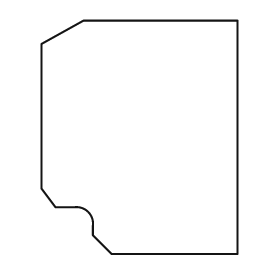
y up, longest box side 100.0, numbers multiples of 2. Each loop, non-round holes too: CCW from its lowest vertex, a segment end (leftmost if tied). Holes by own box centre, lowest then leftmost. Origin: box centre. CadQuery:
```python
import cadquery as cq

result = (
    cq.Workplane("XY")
    .moveTo(-12.0, -50.0)
    .lineTo(42.0, -50.0)
    .lineTo(42.0, 50.0)
    .lineTo(-24.0, 50.0)
    .lineTo(-42.0, 40.0)
    .lineTo(-42.0, -22.0)
    .lineTo(-36.0, -30.0)
    .lineTo(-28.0, -30.0)
    .threePointArc((-22.0, -32.0), (-20.0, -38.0))
    .lineTo(-20.0, -42.0)
    .close()
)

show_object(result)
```